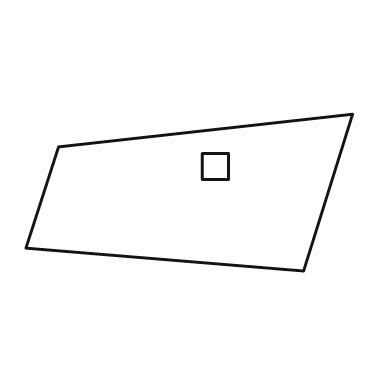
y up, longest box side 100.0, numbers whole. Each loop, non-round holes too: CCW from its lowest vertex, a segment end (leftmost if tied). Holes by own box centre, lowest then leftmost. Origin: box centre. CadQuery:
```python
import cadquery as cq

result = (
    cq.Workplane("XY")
    .moveTo(35.0, -24.0)
    .lineTo(50.0, 24.0)
    .lineTo(-40.0, 14.0)
    .lineTo(-50.0, -17.0)
    .close()
    .moveTo(4.0, 4.0)
    .lineTo(12.0, 4.0)
    .lineTo(12.0, 12.0)
    .lineTo(4.0, 12.0)
    .close()
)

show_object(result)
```